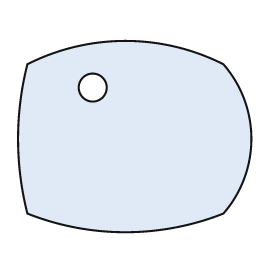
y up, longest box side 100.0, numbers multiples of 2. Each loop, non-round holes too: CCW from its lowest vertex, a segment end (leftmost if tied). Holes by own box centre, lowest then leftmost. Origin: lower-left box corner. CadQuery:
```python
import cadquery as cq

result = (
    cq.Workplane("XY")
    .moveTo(4.0, 8.0)
    .threePointArc((46.0, 0.0), (88.0, 8.0))
    .threePointArc((100.0, 40.0), (88.0, 72.0))
    .threePointArc((46.0, 82.0), (4.0, 72.0))
    .threePointArc((0.0, 40.0), (4.0, 8.0))
    .close()
    .moveTo(32.0, 62.0)
    .circle(6.0)
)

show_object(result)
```